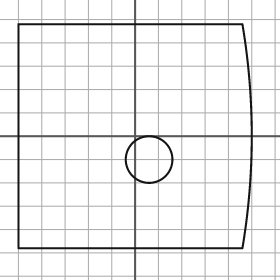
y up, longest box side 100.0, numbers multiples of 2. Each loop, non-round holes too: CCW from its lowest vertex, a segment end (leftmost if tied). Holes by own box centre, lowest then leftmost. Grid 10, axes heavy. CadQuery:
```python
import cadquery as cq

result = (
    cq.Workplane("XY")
    .moveTo(-50.0, -48.0)
    .lineTo(46.0, -48.0)
    .threePointArc((50.0, 0.0), (46.0, 48.0))
    .lineTo(-50.0, 48.0)
    .close()
    .moveTo(6.0, -10.0)
    .circle(10.0)
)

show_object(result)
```